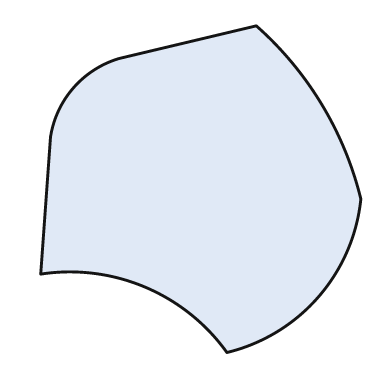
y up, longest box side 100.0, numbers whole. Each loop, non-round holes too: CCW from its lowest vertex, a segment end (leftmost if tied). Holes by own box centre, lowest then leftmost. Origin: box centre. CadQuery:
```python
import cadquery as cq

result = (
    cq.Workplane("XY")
    .moveTo(8.0, -50.0)
    .threePointArc((36.0, -33.0), (49.0, -3.0))
    .threePointArc((37.0, 26.0), (17.0, 50.0))
    .lineTo(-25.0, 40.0)
    .threePointArc((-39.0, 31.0), (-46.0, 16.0))
    .lineTo(-49.0, -26.0)
    .threePointArc((-17.0, -30.0), (8.0, -50.0))
    .close()
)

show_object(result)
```